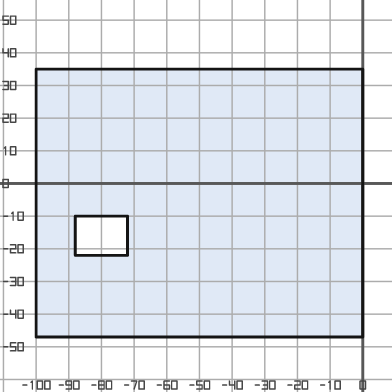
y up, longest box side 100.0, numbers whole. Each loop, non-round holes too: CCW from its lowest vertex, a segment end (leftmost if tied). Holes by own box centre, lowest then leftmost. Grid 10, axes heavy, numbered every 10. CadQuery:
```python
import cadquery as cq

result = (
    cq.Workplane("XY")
    .moveTo(-100.0, -47.0)
    .lineTo(0.0, -47.0)
    .lineTo(0.0, 35.0)
    .lineTo(-100.0, 35.0)
    .close()
    .moveTo(-88.0, -22.0)
    .lineTo(-72.0, -22.0)
    .lineTo(-72.0, -10.0)
    .lineTo(-88.0, -10.0)
    .close()
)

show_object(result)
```